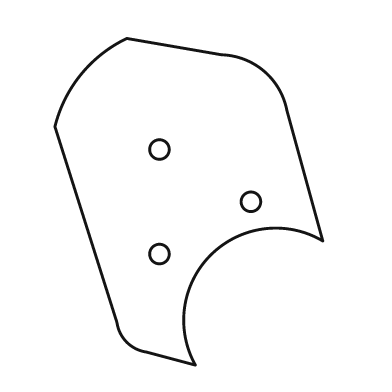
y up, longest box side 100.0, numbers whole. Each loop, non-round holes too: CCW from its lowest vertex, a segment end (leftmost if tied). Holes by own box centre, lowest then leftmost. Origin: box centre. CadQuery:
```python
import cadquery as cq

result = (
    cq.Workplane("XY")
    .moveTo(2.0, -50.0)
    .threePointArc((7.0, -16.0), (41.0, -12.0))
    .lineTo(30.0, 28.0)
    .threePointArc((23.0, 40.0), (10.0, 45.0))
    .lineTo(-19.0, 50.0)
    .threePointArc((-33.0, 39.0), (-41.0, 23.0))
    .lineTo(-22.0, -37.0)
    .threePointArc((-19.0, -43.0), (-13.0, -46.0))
    .close()
    .moveTo(-9.0, -16.0)
    .circle(3.0)
    .moveTo(19.0, 0.0)
    .circle(3.0)
    .moveTo(-9.0, 16.0)
    .circle(3.0)
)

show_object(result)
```